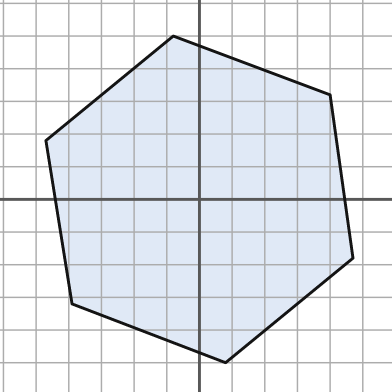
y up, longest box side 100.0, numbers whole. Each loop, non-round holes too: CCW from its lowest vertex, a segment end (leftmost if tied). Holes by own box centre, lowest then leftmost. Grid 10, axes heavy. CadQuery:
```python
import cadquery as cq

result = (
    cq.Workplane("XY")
    .moveTo(8.0, -50.0)
    .lineTo(47.0, -18.0)
    .lineTo(40.0, 32.0)
    .lineTo(-8.0, 50.0)
    .lineTo(-47.0, 18.0)
    .lineTo(-39.0, -32.0)
    .close()
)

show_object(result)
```